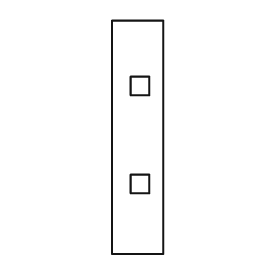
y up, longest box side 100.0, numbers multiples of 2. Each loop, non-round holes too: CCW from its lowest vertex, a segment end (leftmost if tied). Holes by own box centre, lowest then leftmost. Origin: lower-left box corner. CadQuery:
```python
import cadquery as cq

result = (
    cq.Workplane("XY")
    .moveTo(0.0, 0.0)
    .lineTo(22.0, 0.0)
    .lineTo(22.0, 100.0)
    .lineTo(0.0, 100.0)
    .close()
    .moveTo(8.0, 26.0)
    .lineTo(16.0, 26.0)
    .lineTo(16.0, 34.0)
    .lineTo(8.0, 34.0)
    .close()
    .moveTo(8.0, 68.0)
    .lineTo(16.0, 68.0)
    .lineTo(16.0, 76.0)
    .lineTo(8.0, 76.0)
    .close()
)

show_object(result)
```